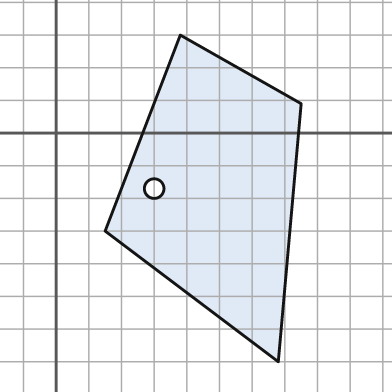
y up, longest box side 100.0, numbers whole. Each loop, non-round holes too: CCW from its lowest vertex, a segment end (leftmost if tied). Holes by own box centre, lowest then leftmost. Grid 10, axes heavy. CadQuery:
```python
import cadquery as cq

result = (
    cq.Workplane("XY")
    .moveTo(68.0, -70.0)
    .lineTo(75.0, 9.0)
    .lineTo(38.0, 30.0)
    .lineTo(15.0, -30.0)
    .close()
    .moveTo(30.0, -17.0)
    .circle(3.0)
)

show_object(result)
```